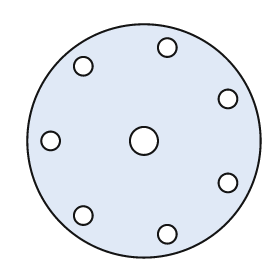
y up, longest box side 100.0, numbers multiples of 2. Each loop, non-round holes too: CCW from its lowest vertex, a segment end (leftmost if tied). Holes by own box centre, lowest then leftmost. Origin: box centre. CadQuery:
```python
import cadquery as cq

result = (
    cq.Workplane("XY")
    .moveTo(0.0, 0.0)
    .circle(50.0)
    .moveTo(10.0, -40.0)
    .circle(4.0)
    .moveTo(-26.0, -32.0)
    .circle(4.0)
    .moveTo(36.0, -18.0)
    .circle(4.0)
    .moveTo(-40.0, 0.0)
    .circle(4.0)
    .moveTo(0.0, 0.0)
    .circle(6.0)
    .moveTo(36.0, 18.0)
    .circle(4.0)
    .moveTo(-26.0, 32.0)
    .circle(4.0)
    .moveTo(10.0, 40.0)
    .circle(4.0)
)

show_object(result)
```